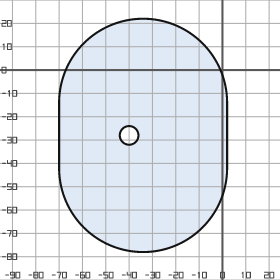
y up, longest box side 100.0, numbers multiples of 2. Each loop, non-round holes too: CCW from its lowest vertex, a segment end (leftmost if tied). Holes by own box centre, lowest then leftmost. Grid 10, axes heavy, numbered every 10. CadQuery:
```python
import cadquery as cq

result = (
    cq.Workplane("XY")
    .moveTo(-70.0, -42.0)
    .threePointArc((-34.0, -78.0), (2.0, -42.0))
    .lineTo(2.0, -14.0)
    .threePointArc((-34.0, 22.0), (-70.0, -14.0))
    .close()
    .moveTo(-40.0, -28.0)
    .circle(4.0)
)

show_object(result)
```